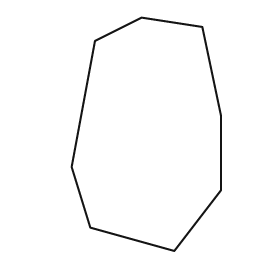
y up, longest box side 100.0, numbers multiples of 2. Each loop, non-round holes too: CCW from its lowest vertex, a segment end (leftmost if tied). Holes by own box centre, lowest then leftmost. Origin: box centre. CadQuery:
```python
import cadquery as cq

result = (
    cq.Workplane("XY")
    .moveTo(12.0, -50.0)
    .lineTo(32.0, -24.0)
    .lineTo(32.0, 8.0)
    .lineTo(24.0, 46.0)
    .lineTo(-2.0, 50.0)
    .lineTo(-22.0, 40.0)
    .lineTo(-32.0, -14.0)
    .lineTo(-24.0, -40.0)
    .close()
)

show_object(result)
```